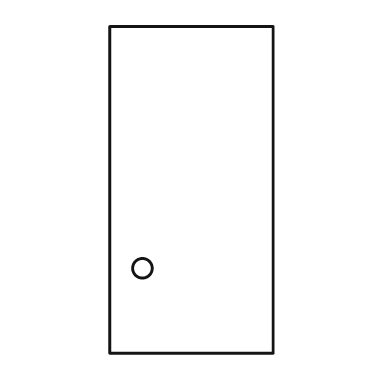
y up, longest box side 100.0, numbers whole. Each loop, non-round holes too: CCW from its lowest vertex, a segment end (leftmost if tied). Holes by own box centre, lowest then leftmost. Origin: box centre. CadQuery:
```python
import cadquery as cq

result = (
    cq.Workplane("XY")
    .moveTo(-25.0, -50.0)
    .lineTo(25.0, -50.0)
    .lineTo(25.0, 50.0)
    .lineTo(-25.0, 50.0)
    .close()
    .moveTo(-15.0, -24.0)
    .circle(3.0)
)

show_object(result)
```